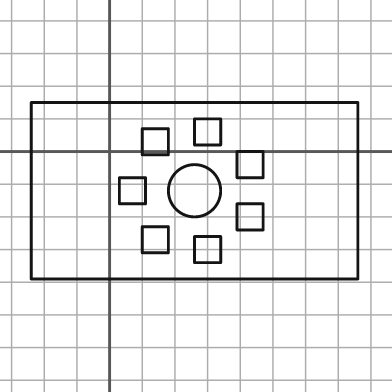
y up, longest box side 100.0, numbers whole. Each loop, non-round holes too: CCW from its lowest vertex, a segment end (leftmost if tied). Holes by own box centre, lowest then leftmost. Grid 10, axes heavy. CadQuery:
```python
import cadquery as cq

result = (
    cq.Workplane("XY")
    .moveTo(-24.0, -39.0)
    .lineTo(76.0, -39.0)
    .lineTo(76.0, 15.0)
    .lineTo(-24.0, 15.0)
    .close()
    .moveTo(26.0, -34.0)
    .lineTo(34.0, -34.0)
    .lineTo(34.0, -26.0)
    .lineTo(26.0, -26.0)
    .close()
    .moveTo(10.0, -31.0)
    .lineTo(18.0, -31.0)
    .lineTo(18.0, -23.0)
    .lineTo(10.0, -23.0)
    .close()
    .moveTo(39.0, -24.0)
    .lineTo(47.0, -24.0)
    .lineTo(47.0, -16.0)
    .lineTo(39.0, -16.0)
    .close()
    .moveTo(3.0, -16.0)
    .lineTo(11.0, -16.0)
    .lineTo(11.0, -8.0)
    .lineTo(3.0, -8.0)
    .close()
    .moveTo(26.0, -12.0)
    .circle(8.0)
    .moveTo(39.0, -8.0)
    .lineTo(47.0, -8.0)
    .lineTo(47.0, 0.0)
    .lineTo(39.0, 0.0)
    .close()
    .moveTo(10.0, -1.0)
    .lineTo(18.0, -1.0)
    .lineTo(18.0, 7.0)
    .lineTo(10.0, 7.0)
    .close()
    .moveTo(26.0, 2.0)
    .lineTo(34.0, 2.0)
    .lineTo(34.0, 10.0)
    .lineTo(26.0, 10.0)
    .close()
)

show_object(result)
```